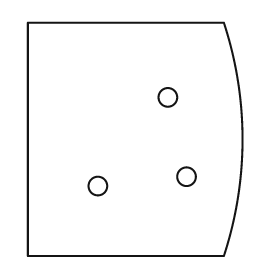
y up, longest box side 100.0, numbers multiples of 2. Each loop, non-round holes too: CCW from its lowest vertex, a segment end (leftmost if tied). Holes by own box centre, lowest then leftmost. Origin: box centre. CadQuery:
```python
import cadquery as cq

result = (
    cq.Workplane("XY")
    .moveTo(-46.0, -50.0)
    .lineTo(38.0, -50.0)
    .threePointArc((46.0, 0.0), (38.0, 50.0))
    .lineTo(-46.0, 50.0)
    .close()
    .moveTo(-16.0, -20.0)
    .circle(4.0)
    .moveTo(22.0, -16.0)
    .circle(4.0)
    .moveTo(14.0, 18.0)
    .circle(4.0)
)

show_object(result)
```